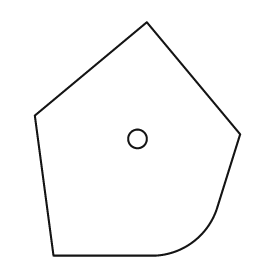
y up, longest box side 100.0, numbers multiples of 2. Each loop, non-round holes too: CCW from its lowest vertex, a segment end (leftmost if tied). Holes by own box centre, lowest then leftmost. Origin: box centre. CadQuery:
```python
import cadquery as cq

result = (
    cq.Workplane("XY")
    .moveTo(-36.0, -50.0)
    .lineTo(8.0, -50.0)
    .threePointArc((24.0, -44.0), (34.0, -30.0))
    .lineTo(44.0, 2.0)
    .lineTo(4.0, 50.0)
    .lineTo(-44.0, 10.0)
    .close()
    .moveTo(0.0, 0.0)
    .circle(4.0)
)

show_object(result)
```